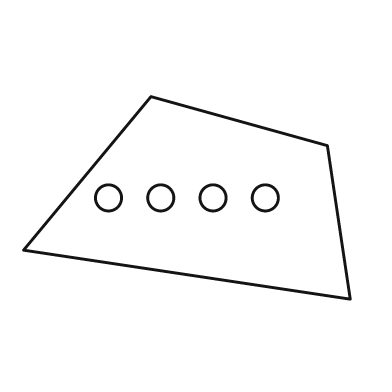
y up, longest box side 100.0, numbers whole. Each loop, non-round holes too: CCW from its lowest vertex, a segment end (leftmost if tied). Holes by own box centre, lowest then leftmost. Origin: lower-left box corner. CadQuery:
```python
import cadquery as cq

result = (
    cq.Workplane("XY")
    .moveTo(100.0, 0.0)
    .lineTo(93.0, 47.0)
    .lineTo(39.0, 62.0)
    .lineTo(0.0, 15.0)
    .close()
    .moveTo(26.0, 31.0)
    .circle(4.0)
    .moveTo(42.0, 31.0)
    .circle(4.0)
    .moveTo(58.0, 31.0)
    .circle(4.0)
    .moveTo(74.0, 31.0)
    .circle(4.0)
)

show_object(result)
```